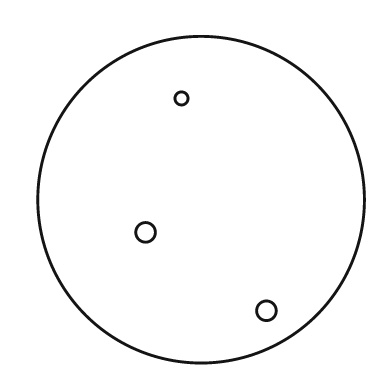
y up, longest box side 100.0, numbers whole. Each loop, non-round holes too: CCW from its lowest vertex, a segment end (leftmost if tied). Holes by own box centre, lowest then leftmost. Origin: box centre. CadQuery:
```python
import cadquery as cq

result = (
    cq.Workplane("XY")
    .moveTo(0.0, 0.0)
    .circle(50.0)
    .moveTo(20.0, -34.0)
    .circle(3.0)
    .moveTo(-17.0, -10.0)
    .circle(3.0)
    .moveTo(-6.0, 31.0)
    .circle(2.0)
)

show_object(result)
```